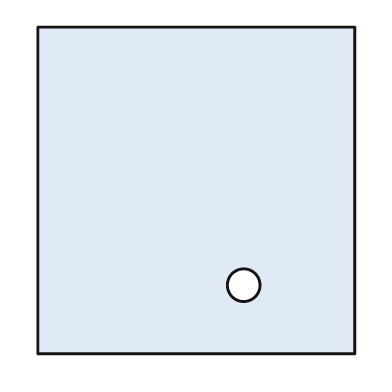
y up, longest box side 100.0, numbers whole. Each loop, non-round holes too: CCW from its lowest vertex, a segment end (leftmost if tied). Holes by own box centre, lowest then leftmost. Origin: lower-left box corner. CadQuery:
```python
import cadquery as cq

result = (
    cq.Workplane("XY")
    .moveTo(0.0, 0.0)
    .lineTo(97.0, 0.0)
    .lineTo(97.0, 100.0)
    .lineTo(0.0, 100.0)
    .close()
    .moveTo(63.0, 21.0)
    .circle(5.0)
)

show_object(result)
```